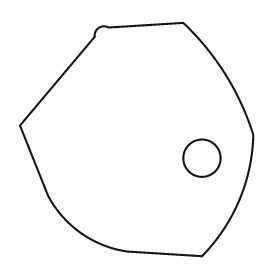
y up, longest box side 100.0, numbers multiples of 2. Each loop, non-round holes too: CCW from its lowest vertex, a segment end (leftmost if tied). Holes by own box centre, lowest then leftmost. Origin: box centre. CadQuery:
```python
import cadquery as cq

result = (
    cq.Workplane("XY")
    .moveTo(28.0, -50.0)
    .threePointArc((44.0, -26.0), (50.0, 2.0))
    .threePointArc((38.0, 28.0), (20.0, 50.0))
    .lineTo(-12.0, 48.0)
    .threePointArc((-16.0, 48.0), (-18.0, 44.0))
    .lineTo(-50.0, 6.0)
    .lineTo(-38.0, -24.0)
    .threePointArc((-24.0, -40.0), (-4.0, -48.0))
    .close()
    .moveTo(28.0, -8.0)
    .circle(8.0)
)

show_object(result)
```